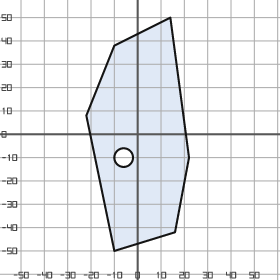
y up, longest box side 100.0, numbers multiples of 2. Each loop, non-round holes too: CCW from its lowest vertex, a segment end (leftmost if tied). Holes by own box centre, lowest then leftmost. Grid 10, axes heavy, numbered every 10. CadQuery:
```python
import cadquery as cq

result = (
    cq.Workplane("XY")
    .moveTo(-10.0, -50.0)
    .lineTo(16.0, -42.0)
    .lineTo(22.0, -10.0)
    .lineTo(14.0, 50.0)
    .lineTo(-10.0, 38.0)
    .lineTo(-22.0, 8.0)
    .close()
    .moveTo(-6.0, -10.0)
    .circle(4.0)
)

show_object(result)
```